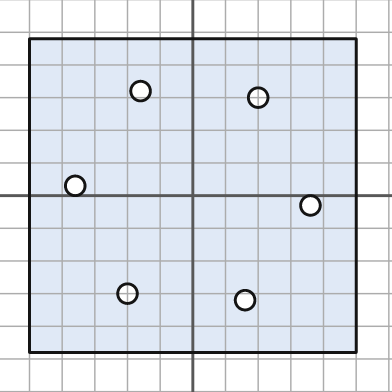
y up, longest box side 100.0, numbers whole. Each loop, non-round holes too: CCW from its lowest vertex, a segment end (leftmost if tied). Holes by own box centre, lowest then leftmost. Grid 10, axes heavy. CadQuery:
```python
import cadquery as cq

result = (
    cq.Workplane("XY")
    .moveTo(-50.0, -48.0)
    .lineTo(50.0, -48.0)
    .lineTo(50.0, 48.0)
    .lineTo(-50.0, 48.0)
    .close()
    .moveTo(16.0, -32.0)
    .circle(3.0)
    .moveTo(-20.0, -30.0)
    .circle(3.0)
    .moveTo(36.0, -3.0)
    .circle(3.0)
    .moveTo(-36.0, 3.0)
    .circle(3.0)
    .moveTo(20.0, 30.0)
    .circle(3.0)
    .moveTo(-16.0, 32.0)
    .circle(3.0)
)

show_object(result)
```